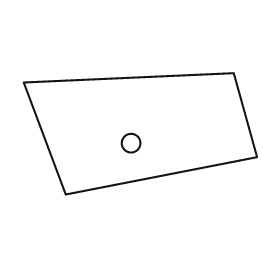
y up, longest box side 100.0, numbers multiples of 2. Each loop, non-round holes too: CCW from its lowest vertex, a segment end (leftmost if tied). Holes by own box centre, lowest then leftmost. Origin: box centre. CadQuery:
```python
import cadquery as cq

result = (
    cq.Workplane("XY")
    .moveTo(-32.0, -26.0)
    .lineTo(50.0, -10.0)
    .lineTo(40.0, 26.0)
    .lineTo(-50.0, 22.0)
    .close()
    .moveTo(-4.0, -4.0)
    .circle(4.0)
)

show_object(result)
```